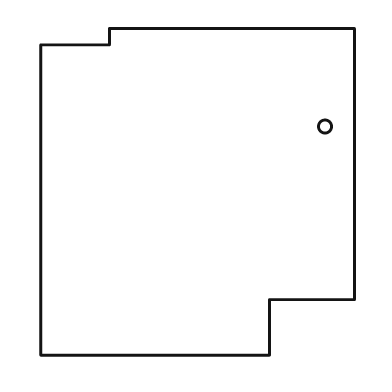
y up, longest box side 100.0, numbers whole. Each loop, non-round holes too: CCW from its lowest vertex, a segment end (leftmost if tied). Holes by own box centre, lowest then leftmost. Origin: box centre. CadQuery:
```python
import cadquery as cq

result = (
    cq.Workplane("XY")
    .moveTo(-48.0, -50.0)
    .lineTo(22.0, -50.0)
    .lineTo(22.0, -33.0)
    .lineTo(48.0, -33.0)
    .lineTo(48.0, 50.0)
    .lineTo(-27.0, 50.0)
    .lineTo(-27.0, 45.0)
    .lineTo(-48.0, 45.0)
    .close()
    .moveTo(39.0, 20.0)
    .circle(2.0)
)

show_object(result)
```